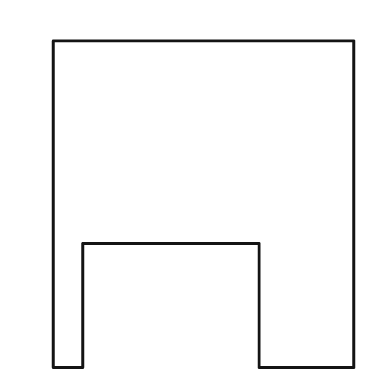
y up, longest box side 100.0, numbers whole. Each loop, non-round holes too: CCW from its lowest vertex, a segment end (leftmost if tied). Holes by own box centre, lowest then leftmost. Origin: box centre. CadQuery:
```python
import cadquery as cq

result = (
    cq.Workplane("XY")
    .moveTo(-46.0, -50.0)
    .lineTo(-37.0, -50.0)
    .lineTo(-37.0, -12.0)
    .lineTo(17.0, -12.0)
    .lineTo(17.0, -50.0)
    .lineTo(46.0, -50.0)
    .lineTo(46.0, 50.0)
    .lineTo(-46.0, 50.0)
    .close()
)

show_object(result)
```